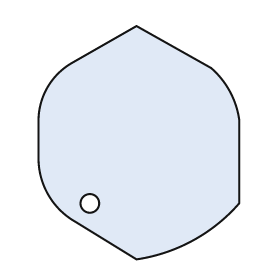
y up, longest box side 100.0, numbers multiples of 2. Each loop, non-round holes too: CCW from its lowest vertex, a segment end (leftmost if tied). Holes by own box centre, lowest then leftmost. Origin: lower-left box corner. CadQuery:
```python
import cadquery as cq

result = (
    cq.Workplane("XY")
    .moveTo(42.0, 0.0)
    .threePointArc((66.0, 8.0), (86.0, 24.0))
    .lineTo(86.0, 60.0)
    .threePointArc((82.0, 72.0), (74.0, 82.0))
    .lineTo(42.0, 100.0)
    .lineTo(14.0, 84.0)
    .threePointArc((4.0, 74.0), (0.0, 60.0))
    .lineTo(0.0, 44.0)
    .threePointArc((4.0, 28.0), (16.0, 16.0))
    .close()
    .moveTo(22.0, 24.0)
    .circle(4.0)
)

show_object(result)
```